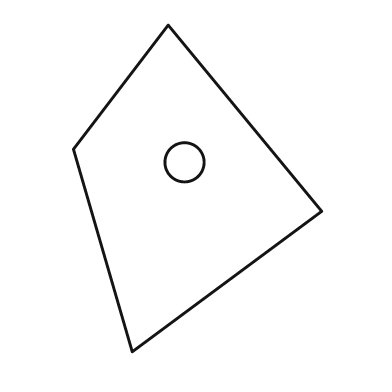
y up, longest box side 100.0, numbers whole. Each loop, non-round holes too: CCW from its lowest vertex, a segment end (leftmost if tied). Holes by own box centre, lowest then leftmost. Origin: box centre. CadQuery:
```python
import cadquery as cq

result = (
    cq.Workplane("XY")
    .moveTo(-20.0, -50.0)
    .lineTo(38.0, -7.0)
    .lineTo(-9.0, 50.0)
    .lineTo(-38.0, 12.0)
    .close()
    .moveTo(-4.0, 8.0)
    .circle(6.0)
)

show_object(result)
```